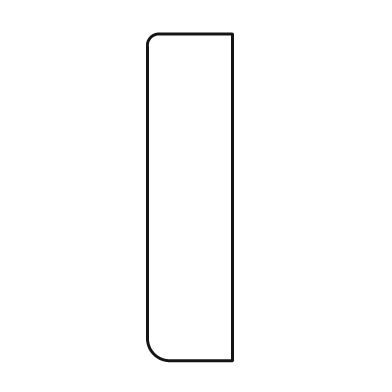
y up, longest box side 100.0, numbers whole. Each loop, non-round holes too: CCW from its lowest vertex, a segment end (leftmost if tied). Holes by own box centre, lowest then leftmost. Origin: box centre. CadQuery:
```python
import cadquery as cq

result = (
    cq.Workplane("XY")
    .moveTo(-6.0, -50.0)
    .lineTo(13.0, -50.0)
    .lineTo(13.0, 50.0)
    .lineTo(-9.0, 50.0)
    .threePointArc((-12.0, 49.0), (-13.0, 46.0))
    .lineTo(-13.0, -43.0)
    .threePointArc((-11.0, -48.0), (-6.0, -50.0))
    .close()
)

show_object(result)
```